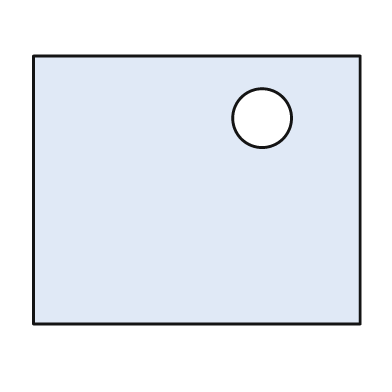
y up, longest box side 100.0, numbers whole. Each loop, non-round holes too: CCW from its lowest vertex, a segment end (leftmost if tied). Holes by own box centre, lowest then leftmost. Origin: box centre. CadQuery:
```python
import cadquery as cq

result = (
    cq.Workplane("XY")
    .moveTo(-50.0, -41.0)
    .lineTo(50.0, -41.0)
    .lineTo(50.0, 41.0)
    .lineTo(-50.0, 41.0)
    .close()
    .moveTo(20.0, 22.0)
    .circle(9.0)
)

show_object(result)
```